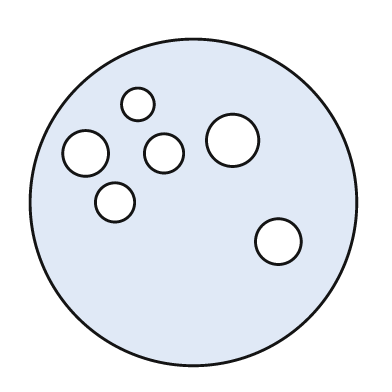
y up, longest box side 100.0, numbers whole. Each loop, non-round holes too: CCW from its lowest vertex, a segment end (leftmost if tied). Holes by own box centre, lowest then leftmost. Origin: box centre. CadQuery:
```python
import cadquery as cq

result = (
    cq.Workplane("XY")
    .moveTo(0.0, 0.0)
    .circle(50.0)
    .moveTo(26.0, -12.0)
    .circle(7.0)
    .moveTo(-24.0, 0.0)
    .circle(6.0)
    .moveTo(-33.0, 15.0)
    .circle(7.0)
    .moveTo(-9.0, 15.0)
    .circle(6.0)
    .moveTo(12.0, 19.0)
    .circle(8.0)
    .moveTo(-17.0, 30.0)
    .circle(5.0)
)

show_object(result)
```